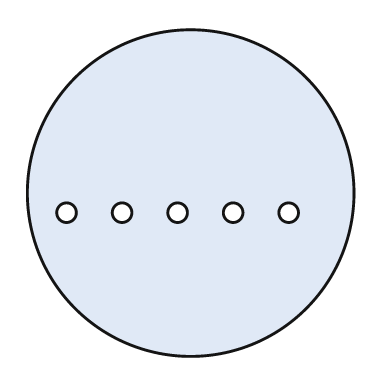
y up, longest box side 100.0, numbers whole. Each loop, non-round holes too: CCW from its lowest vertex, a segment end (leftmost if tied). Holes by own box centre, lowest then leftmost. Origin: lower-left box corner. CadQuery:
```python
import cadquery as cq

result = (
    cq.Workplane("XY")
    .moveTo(50.0, 50.0)
    .circle(50.0)
    .moveTo(12.0, 44.0)
    .circle(3.0)
    .moveTo(29.0, 44.0)
    .circle(3.0)
    .moveTo(46.0, 44.0)
    .circle(3.0)
    .moveTo(63.0, 44.0)
    .circle(3.0)
    .moveTo(80.0, 44.0)
    .circle(3.0)
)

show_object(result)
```